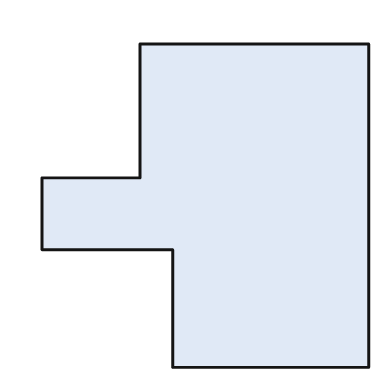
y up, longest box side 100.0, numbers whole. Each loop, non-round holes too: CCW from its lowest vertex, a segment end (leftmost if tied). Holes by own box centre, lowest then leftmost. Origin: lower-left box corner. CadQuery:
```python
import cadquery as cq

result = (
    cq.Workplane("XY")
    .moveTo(40.0, 0.0)
    .lineTo(100.0, 0.0)
    .lineTo(100.0, 99.0)
    .lineTo(30.0, 99.0)
    .lineTo(30.0, 58.0)
    .lineTo(0.0, 58.0)
    .lineTo(0.0, 36.0)
    .lineTo(40.0, 36.0)
    .close()
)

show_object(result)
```